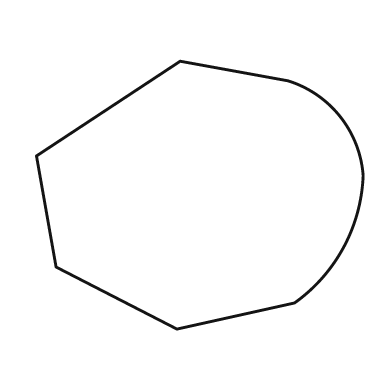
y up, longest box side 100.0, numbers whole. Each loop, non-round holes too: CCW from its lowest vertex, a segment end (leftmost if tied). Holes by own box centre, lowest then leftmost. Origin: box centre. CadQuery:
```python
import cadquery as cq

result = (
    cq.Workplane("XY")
    .moveTo(-7.0, -41.0)
    .lineTo(29.0, -33.0)
    .threePointArc((44.0, -16.0), (50.0, 6.0))
    .threePointArc((43.0, 24.0), (27.0, 35.0))
    .lineTo(-6.0, 41.0)
    .lineTo(-50.0, 12.0)
    .lineTo(-44.0, -22.0)
    .close()
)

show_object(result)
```